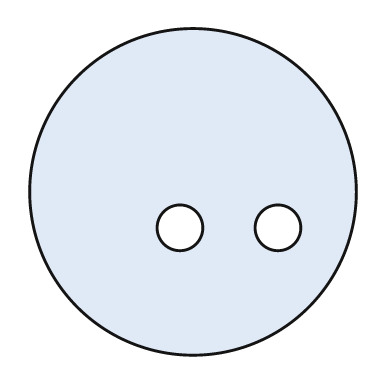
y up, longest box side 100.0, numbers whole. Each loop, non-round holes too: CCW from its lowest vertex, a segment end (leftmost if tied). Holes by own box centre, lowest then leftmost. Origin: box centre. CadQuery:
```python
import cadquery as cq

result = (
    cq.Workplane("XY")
    .moveTo(0.0, 0.0)
    .circle(50.0)
    .moveTo(-4.0, -11.0)
    .circle(7.0)
    .moveTo(26.0, -11.0)
    .circle(7.0)
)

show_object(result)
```